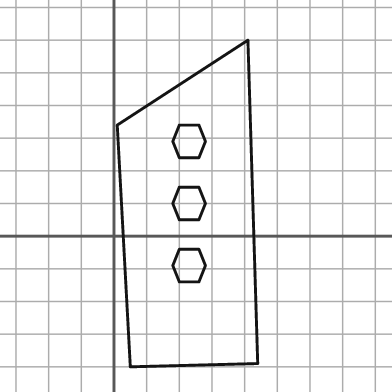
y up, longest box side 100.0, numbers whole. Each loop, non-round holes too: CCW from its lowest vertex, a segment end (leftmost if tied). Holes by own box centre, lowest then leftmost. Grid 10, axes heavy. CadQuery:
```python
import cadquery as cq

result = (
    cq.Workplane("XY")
    .moveTo(5.0, -40.0)
    .lineTo(44.0, -39.0)
    .lineTo(41.0, 60.0)
    .lineTo(1.0, 34.0)
    .close()
    .moveTo(20.0, -14.0)
    .lineTo(26.0, -14.0)
    .lineTo(28.0, -9.0)
    .lineTo(26.0, -4.0)
    .lineTo(20.0, -4.0)
    .lineTo(18.0, -9.0)
    .close()
    .moveTo(20.0, 5.0)
    .lineTo(26.0, 5.0)
    .lineTo(28.0, 10.0)
    .lineTo(26.0, 15.0)
    .lineTo(20.0, 15.0)
    .lineTo(18.0, 10.0)
    .close()
    .moveTo(20.0, 24.0)
    .lineTo(26.0, 24.0)
    .lineTo(28.0, 29.0)
    .lineTo(26.0, 34.0)
    .lineTo(20.0, 34.0)
    .lineTo(18.0, 29.0)
    .close()
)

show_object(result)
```